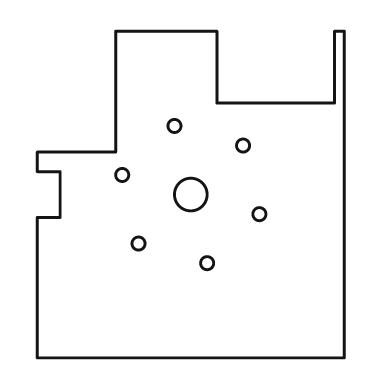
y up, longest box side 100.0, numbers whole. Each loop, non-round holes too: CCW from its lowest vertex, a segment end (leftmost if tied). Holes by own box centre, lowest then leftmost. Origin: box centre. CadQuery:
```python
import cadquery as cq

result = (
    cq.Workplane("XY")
    .moveTo(-47.0, -50.0)
    .lineTo(47.0, -50.0)
    .lineTo(47.0, 50.0)
    .lineTo(44.0, 50.0)
    .lineTo(44.0, 28.0)
    .lineTo(8.0, 28.0)
    .lineTo(8.0, 50.0)
    .lineTo(-23.0, 50.0)
    .lineTo(-23.0, 13.0)
    .lineTo(-47.0, 13.0)
    .lineTo(-47.0, 7.0)
    .lineTo(-40.0, 7.0)
    .lineTo(-40.0, -7.0)
    .lineTo(-47.0, -7.0)
    .close()
    .moveTo(5.0, -21.0)
    .circle(2.0)
    .moveTo(-16.0, -15.0)
    .circle(2.0)
    .moveTo(21.0, -6.0)
    .circle(2.0)
    .moveTo(0.0, 0.0)
    .circle(5.0)
    .moveTo(-21.0, 6.0)
    .circle(2.0)
    .moveTo(16.0, 15.0)
    .circle(2.0)
    .moveTo(-5.0, 21.0)
    .circle(2.0)
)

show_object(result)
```